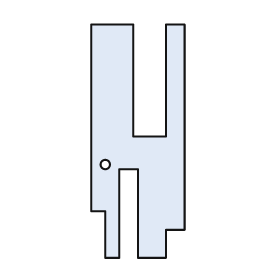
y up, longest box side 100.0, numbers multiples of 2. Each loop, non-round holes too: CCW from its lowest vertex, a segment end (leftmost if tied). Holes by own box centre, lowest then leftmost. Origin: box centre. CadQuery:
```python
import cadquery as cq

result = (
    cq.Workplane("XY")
    .moveTo(-14.0, -50.0)
    .lineTo(-8.0, -50.0)
    .lineTo(-8.0, -12.0)
    .lineTo(0.0, -12.0)
    .lineTo(0.0, -50.0)
    .lineTo(12.0, -50.0)
    .lineTo(12.0, -38.0)
    .lineTo(20.0, -38.0)
    .lineTo(20.0, 50.0)
    .lineTo(12.0, 50.0)
    .lineTo(12.0, 2.0)
    .lineTo(-2.0, 2.0)
    .lineTo(-2.0, 50.0)
    .lineTo(-20.0, 50.0)
    .lineTo(-20.0, -30.0)
    .lineTo(-14.0, -30.0)
    .close()
    .moveTo(-14.0, -10.0)
    .circle(2.0)
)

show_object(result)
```